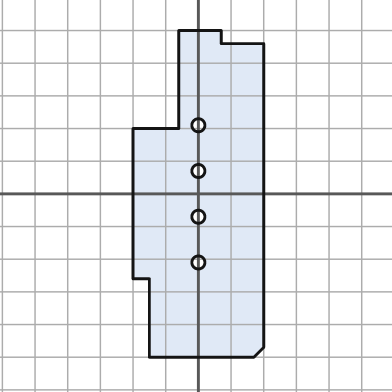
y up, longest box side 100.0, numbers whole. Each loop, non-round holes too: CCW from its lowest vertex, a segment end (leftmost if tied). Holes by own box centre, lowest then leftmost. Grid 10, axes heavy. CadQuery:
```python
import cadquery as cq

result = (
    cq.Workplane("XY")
    .moveTo(-15.0, -50.0)
    .lineTo(17.0, -50.0)
    .lineTo(20.0, -47.0)
    .lineTo(20.0, 46.0)
    .lineTo(7.0, 46.0)
    .lineTo(7.0, 50.0)
    .lineTo(-6.0, 50.0)
    .lineTo(-6.0, 20.0)
    .lineTo(-20.0, 20.0)
    .lineTo(-20.0, -26.0)
    .lineTo(-15.0, -26.0)
    .close()
    .moveTo(0.0, -21.0)
    .circle(2.0)
    .moveTo(0.0, -7.0)
    .circle(2.0)
    .moveTo(0.0, 7.0)
    .circle(2.0)
    .moveTo(0.0, 21.0)
    .circle(2.0)
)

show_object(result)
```